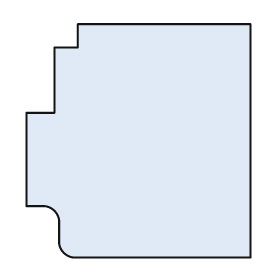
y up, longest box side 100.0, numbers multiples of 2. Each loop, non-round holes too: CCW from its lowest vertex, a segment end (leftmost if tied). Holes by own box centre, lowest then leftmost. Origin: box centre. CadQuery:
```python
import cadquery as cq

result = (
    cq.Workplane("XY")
    .moveTo(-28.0, -50.0)
    .lineTo(48.0, -50.0)
    .lineTo(48.0, 50.0)
    .lineTo(-26.0, 50.0)
    .lineTo(-26.0, 40.0)
    .lineTo(-36.0, 40.0)
    .lineTo(-36.0, 12.0)
    .lineTo(-48.0, 12.0)
    .lineTo(-48.0, -28.0)
    .lineTo(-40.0, -28.0)
    .threePointArc((-36.0, -30.0), (-34.0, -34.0))
    .lineTo(-34.0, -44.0)
    .threePointArc((-32.0, -48.0), (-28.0, -50.0))
    .close()
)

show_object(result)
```